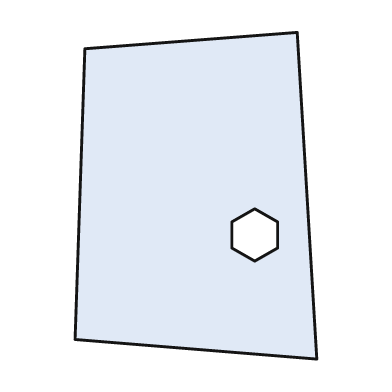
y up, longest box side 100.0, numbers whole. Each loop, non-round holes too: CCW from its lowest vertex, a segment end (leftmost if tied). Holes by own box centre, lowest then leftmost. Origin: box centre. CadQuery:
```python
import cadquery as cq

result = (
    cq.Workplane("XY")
    .moveTo(37.0, -50.0)
    .lineTo(31.0, 50.0)
    .lineTo(-34.0, 45.0)
    .lineTo(-37.0, -44.0)
    .close()
    .moveTo(18.0, -20.0)
    .lineTo(25.0, -16.0)
    .lineTo(25.0, -8.0)
    .lineTo(18.0, -4.0)
    .lineTo(11.0, -8.0)
    .lineTo(11.0, -16.0)
    .close()
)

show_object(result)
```